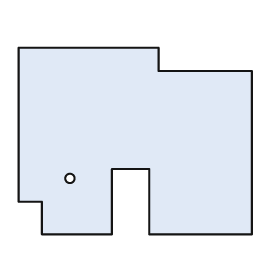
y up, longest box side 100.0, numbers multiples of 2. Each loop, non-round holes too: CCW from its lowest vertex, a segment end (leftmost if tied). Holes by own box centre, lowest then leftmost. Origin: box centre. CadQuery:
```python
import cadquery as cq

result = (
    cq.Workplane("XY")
    .moveTo(-40.0, -40.0)
    .lineTo(-10.0, -40.0)
    .lineTo(-10.0, -12.0)
    .lineTo(6.0, -12.0)
    .lineTo(6.0, -40.0)
    .lineTo(50.0, -40.0)
    .lineTo(50.0, 30.0)
    .lineTo(10.0, 30.0)
    .lineTo(10.0, 40.0)
    .lineTo(-50.0, 40.0)
    .lineTo(-50.0, -26.0)
    .lineTo(-40.0, -26.0)
    .close()
    .moveTo(-28.0, -16.0)
    .circle(2.0)
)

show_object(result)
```